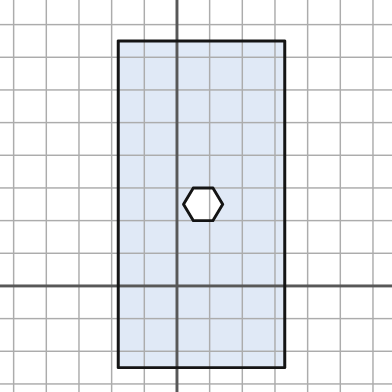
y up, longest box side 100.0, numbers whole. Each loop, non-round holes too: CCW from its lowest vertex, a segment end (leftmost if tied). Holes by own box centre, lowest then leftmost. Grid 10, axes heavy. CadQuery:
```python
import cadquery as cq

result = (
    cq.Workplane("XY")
    .moveTo(-18.0, -25.0)
    .lineTo(33.0, -25.0)
    .lineTo(33.0, 75.0)
    .lineTo(-18.0, 75.0)
    .close()
    .moveTo(5.0, 20.0)
    .lineTo(11.0, 20.0)
    .lineTo(14.0, 25.0)
    .lineTo(11.0, 30.0)
    .lineTo(5.0, 30.0)
    .lineTo(2.0, 25.0)
    .close()
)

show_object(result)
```